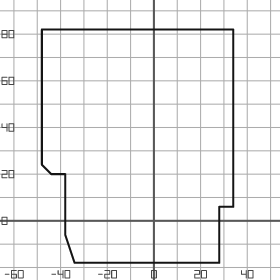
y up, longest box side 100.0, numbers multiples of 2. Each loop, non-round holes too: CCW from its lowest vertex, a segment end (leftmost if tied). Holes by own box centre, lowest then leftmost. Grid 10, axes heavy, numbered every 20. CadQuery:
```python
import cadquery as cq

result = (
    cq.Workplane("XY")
    .moveTo(-34.0, -18.0)
    .lineTo(28.0, -18.0)
    .lineTo(28.0, 6.0)
    .lineTo(34.0, 6.0)
    .lineTo(34.0, 82.0)
    .lineTo(-48.0, 82.0)
    .lineTo(-48.0, 24.0)
    .lineTo(-44.0, 20.0)
    .lineTo(-38.0, 20.0)
    .lineTo(-38.0, -6.0)
    .close()
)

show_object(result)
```